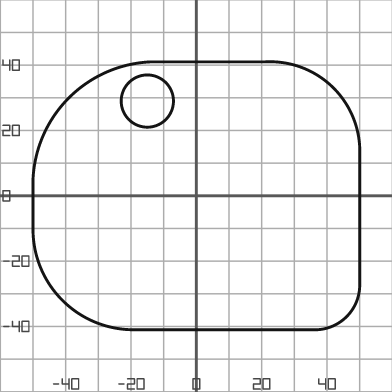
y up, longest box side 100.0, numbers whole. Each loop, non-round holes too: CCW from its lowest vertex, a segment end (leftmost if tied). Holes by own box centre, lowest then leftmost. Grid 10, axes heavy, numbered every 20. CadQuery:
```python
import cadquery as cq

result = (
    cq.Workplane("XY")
    .moveTo(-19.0, -41.0)
    .lineTo(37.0, -41.0)
    .threePointArc((46.0, -37.0), (50.0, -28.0))
    .lineTo(50.0, 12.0)
    .threePointArc((42.0, 33.0), (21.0, 41.0))
    .lineTo(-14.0, 41.0)
    .threePointArc((-39.0, 30.0), (-50.0, 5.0))
    .lineTo(-50.0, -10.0)
    .threePointArc((-41.0, -32.0), (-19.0, -41.0))
    .close()
    .moveTo(-15.0, 29.0)
    .circle(8.0)
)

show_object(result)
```